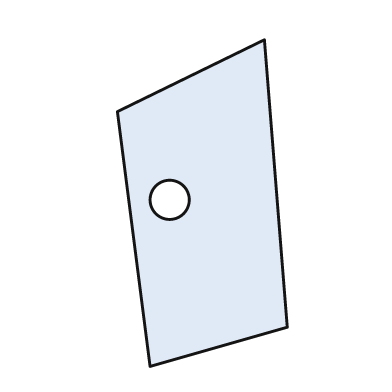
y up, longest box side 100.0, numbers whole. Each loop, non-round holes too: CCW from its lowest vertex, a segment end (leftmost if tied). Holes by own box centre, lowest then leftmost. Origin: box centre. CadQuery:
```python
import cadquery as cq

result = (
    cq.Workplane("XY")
    .moveTo(-16.0, -50.0)
    .lineTo(26.0, -38.0)
    .lineTo(19.0, 50.0)
    .lineTo(-26.0, 28.0)
    .close()
    .moveTo(-10.0, 1.0)
    .circle(6.0)
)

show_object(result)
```